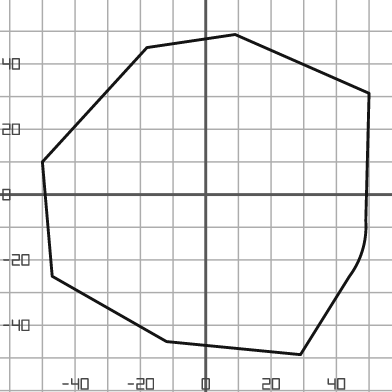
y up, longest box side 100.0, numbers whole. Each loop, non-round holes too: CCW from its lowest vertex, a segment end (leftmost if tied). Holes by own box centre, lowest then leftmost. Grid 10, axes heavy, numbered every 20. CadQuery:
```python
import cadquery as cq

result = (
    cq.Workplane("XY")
    .moveTo(29.0, -49.0)
    .lineTo(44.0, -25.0)
    .threePointArc((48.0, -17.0), (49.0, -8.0))
    .lineTo(50.0, 31.0)
    .lineTo(9.0, 49.0)
    .lineTo(-18.0, 45.0)
    .lineTo(-50.0, 10.0)
    .lineTo(-47.0, -25.0)
    .lineTo(-12.0, -45.0)
    .close()
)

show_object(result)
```